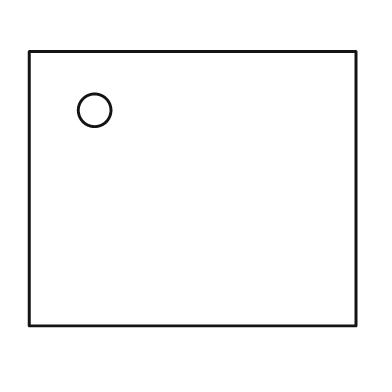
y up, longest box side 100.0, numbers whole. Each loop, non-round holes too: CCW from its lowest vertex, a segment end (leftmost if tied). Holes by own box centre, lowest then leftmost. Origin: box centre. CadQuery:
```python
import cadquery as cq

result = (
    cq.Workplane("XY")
    .moveTo(-50.0, -42.0)
    .lineTo(50.0, -42.0)
    .lineTo(50.0, 42.0)
    .lineTo(-50.0, 42.0)
    .close()
    .moveTo(-30.0, 24.0)
    .circle(5.0)
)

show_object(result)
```